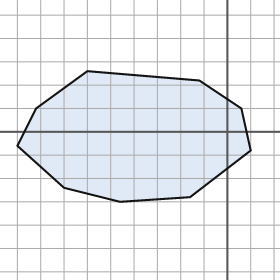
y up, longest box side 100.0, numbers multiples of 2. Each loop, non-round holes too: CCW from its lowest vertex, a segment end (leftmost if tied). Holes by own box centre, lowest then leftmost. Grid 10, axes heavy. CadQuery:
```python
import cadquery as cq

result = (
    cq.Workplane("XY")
    .moveTo(-46.0, -30.0)
    .lineTo(-16.0, -28.0)
    .lineTo(10.0, -8.0)
    .lineTo(6.0, 10.0)
    .lineTo(-12.0, 22.0)
    .lineTo(-60.0, 26.0)
    .lineTo(-82.0, 10.0)
    .lineTo(-90.0, -6.0)
    .lineTo(-70.0, -24.0)
    .close()
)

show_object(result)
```